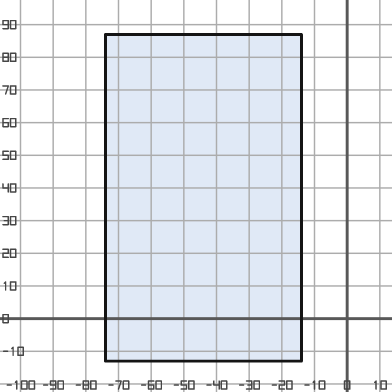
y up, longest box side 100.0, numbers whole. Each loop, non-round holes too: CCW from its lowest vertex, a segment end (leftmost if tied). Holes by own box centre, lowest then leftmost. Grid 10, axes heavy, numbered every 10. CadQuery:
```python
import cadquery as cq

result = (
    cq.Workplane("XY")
    .moveTo(-74.0, -13.0)
    .lineTo(-14.0, -13.0)
    .lineTo(-14.0, 87.0)
    .lineTo(-74.0, 87.0)
    .close()
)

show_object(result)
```